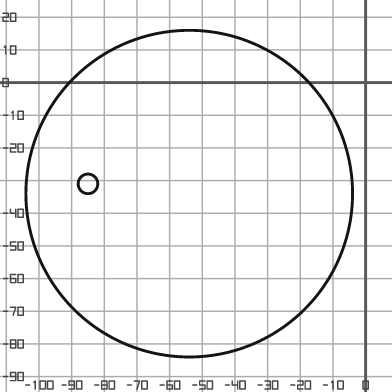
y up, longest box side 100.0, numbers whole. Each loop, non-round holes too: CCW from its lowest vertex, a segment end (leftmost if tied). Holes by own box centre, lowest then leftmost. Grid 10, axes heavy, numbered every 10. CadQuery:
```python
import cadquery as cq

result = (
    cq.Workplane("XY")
    .moveTo(-54.0, -34.0)
    .circle(50.0)
    .moveTo(-85.0, -31.0)
    .circle(3.0)
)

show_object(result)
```